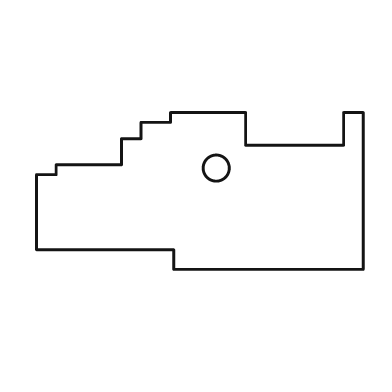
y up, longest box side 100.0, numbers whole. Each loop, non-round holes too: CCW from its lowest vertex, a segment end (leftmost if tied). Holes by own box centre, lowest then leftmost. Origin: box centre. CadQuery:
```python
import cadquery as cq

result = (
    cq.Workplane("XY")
    .moveTo(-8.0, -24.0)
    .lineTo(50.0, -24.0)
    .lineTo(50.0, 24.0)
    .lineTo(44.0, 24.0)
    .lineTo(44.0, 14.0)
    .lineTo(14.0, 14.0)
    .lineTo(14.0, 24.0)
    .lineTo(-9.0, 24.0)
    .lineTo(-9.0, 21.0)
    .lineTo(-18.0, 21.0)
    .lineTo(-18.0, 16.0)
    .lineTo(-24.0, 16.0)
    .lineTo(-24.0, 8.0)
    .lineTo(-44.0, 8.0)
    .lineTo(-44.0, 5.0)
    .lineTo(-50.0, 5.0)
    .lineTo(-50.0, -18.0)
    .lineTo(-8.0, -18.0)
    .close()
    .moveTo(5.0, 7.0)
    .circle(4.0)
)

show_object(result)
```